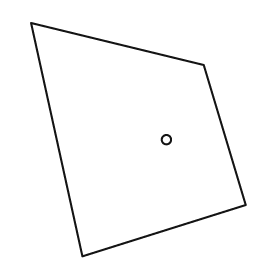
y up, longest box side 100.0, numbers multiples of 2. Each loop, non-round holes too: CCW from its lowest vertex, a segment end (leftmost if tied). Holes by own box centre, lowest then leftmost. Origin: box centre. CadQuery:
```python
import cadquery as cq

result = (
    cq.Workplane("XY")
    .moveTo(-24.0, -50.0)
    .lineTo(46.0, -28.0)
    .lineTo(28.0, 32.0)
    .lineTo(-46.0, 50.0)
    .close()
    .moveTo(12.0, 0.0)
    .circle(2.0)
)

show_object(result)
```